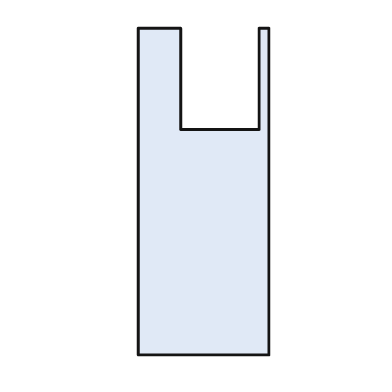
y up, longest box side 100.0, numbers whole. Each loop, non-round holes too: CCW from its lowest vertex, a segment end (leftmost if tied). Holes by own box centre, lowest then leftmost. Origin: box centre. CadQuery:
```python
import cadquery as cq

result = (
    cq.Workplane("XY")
    .moveTo(-20.0, -50.0)
    .lineTo(20.0, -50.0)
    .lineTo(20.0, 50.0)
    .lineTo(17.0, 50.0)
    .lineTo(17.0, 19.0)
    .lineTo(-7.0, 19.0)
    .lineTo(-7.0, 50.0)
    .lineTo(-20.0, 50.0)
    .close()
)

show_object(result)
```